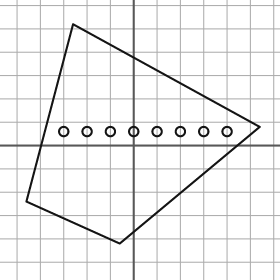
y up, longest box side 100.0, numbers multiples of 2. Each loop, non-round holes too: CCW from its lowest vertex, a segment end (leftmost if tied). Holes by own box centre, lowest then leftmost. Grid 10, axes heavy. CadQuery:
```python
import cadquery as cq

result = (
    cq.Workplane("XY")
    .moveTo(-6.0, -42.0)
    .lineTo(54.0, 8.0)
    .lineTo(-26.0, 52.0)
    .lineTo(-46.0, -24.0)
    .close()
    .moveTo(-30.0, 6.0)
    .circle(2.0)
    .moveTo(-20.0, 6.0)
    .circle(2.0)
    .moveTo(-10.0, 6.0)
    .circle(2.0)
    .moveTo(0.0, 6.0)
    .circle(2.0)
    .moveTo(10.0, 6.0)
    .circle(2.0)
    .moveTo(20.0, 6.0)
    .circle(2.0)
    .moveTo(30.0, 6.0)
    .circle(2.0)
    .moveTo(40.0, 6.0)
    .circle(2.0)
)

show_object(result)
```